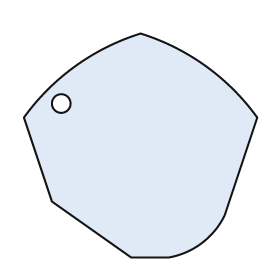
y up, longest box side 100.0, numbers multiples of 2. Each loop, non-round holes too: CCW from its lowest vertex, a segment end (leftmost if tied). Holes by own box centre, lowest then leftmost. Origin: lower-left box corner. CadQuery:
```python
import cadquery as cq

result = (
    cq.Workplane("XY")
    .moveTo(46.0, 0.0)
    .lineTo(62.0, 0.0)
    .threePointArc((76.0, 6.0), (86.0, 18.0))
    .lineTo(100.0, 60.0)
    .threePointArc((78.0, 82.0), (50.0, 96.0))
    .threePointArc((22.0, 82.0), (0.0, 60.0))
    .lineTo(12.0, 24.0)
    .close()
    .moveTo(16.0, 66.0)
    .circle(4.0)
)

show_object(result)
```